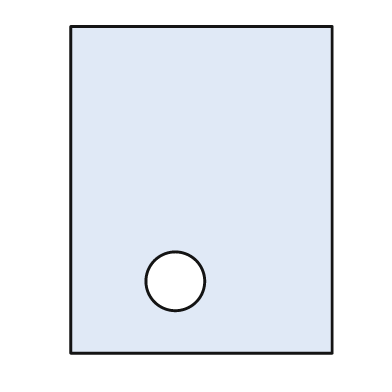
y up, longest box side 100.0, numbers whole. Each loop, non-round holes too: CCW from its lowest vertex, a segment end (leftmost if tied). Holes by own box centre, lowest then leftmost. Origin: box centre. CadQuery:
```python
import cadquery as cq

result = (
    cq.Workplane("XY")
    .moveTo(-40.0, -50.0)
    .lineTo(40.0, -50.0)
    .lineTo(40.0, 50.0)
    .lineTo(-40.0, 50.0)
    .close()
    .moveTo(-8.0, -28.0)
    .circle(9.0)
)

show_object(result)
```